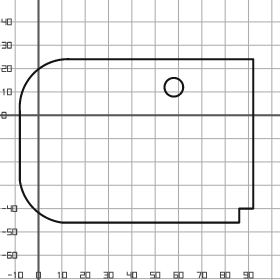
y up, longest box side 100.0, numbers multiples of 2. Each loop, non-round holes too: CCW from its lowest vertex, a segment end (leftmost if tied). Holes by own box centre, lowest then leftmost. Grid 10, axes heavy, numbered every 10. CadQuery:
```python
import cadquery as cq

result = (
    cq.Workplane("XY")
    .moveTo(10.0, -46.0)
    .lineTo(86.0, -46.0)
    .lineTo(86.0, -40.0)
    .lineTo(92.0, -40.0)
    .lineTo(92.0, 24.0)
    .lineTo(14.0, 24.0)
    .threePointArc((-2.0, 18.0), (-8.0, 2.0))
    .lineTo(-8.0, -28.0)
    .threePointArc((-2.0, -40.0), (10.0, -46.0))
    .close()
    .moveTo(58.0, 12.0)
    .circle(4.0)
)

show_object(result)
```